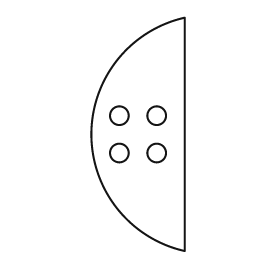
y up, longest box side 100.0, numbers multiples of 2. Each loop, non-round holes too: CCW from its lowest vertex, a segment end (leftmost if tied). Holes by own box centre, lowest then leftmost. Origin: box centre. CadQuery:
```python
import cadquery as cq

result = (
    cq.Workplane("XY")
    .moveTo(20.0, -50.0)
    .lineTo(20.0, 50.0)
    .threePointArc((-20.0, 0.0), (20.0, -50.0))
    .close()
    .moveTo(-8.0, -8.0)
    .circle(4.0)
    .moveTo(8.0, -8.0)
    .circle(4.0)
    .moveTo(-8.0, 8.0)
    .circle(4.0)
    .moveTo(8.0, 8.0)
    .circle(4.0)
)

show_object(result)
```